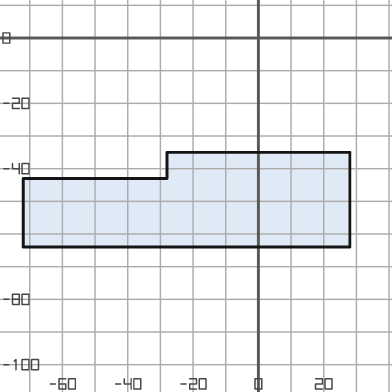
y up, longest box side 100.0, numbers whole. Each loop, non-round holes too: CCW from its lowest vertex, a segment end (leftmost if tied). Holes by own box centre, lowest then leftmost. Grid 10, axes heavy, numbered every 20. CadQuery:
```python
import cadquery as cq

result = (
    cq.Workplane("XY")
    .moveTo(-72.0, -64.0)
    .lineTo(28.0, -64.0)
    .lineTo(28.0, -35.0)
    .lineTo(-28.0, -35.0)
    .lineTo(-28.0, -43.0)
    .lineTo(-72.0, -43.0)
    .close()
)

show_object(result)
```